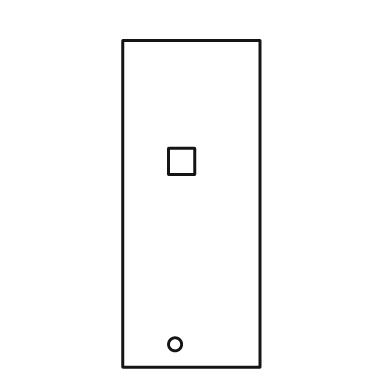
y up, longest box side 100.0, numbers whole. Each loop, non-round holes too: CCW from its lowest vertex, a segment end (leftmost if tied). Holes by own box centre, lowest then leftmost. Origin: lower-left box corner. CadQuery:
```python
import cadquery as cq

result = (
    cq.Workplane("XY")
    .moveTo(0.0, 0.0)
    .lineTo(42.0, 0.0)
    .lineTo(42.0, 100.0)
    .lineTo(0.0, 100.0)
    .close()
    .moveTo(16.0, 7.0)
    .circle(2.0)
    .moveTo(14.0, 59.0)
    .lineTo(22.0, 59.0)
    .lineTo(22.0, 67.0)
    .lineTo(14.0, 67.0)
    .close()
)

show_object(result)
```